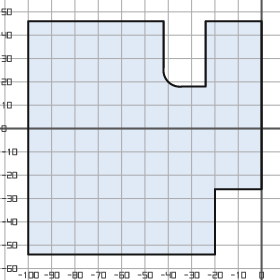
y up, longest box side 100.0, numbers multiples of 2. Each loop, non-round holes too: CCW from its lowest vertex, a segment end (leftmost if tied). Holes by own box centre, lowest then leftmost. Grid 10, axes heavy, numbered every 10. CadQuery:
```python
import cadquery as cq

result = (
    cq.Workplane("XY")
    .moveTo(-100.0, -54.0)
    .lineTo(-20.0, -54.0)
    .lineTo(-20.0, -26.0)
    .lineTo(0.0, -26.0)
    .lineTo(0.0, 46.0)
    .lineTo(-24.0, 46.0)
    .lineTo(-24.0, 18.0)
    .lineTo(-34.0, 18.0)
    .threePointArc((-40.0, 20.0), (-42.0, 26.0))
    .lineTo(-42.0, 46.0)
    .lineTo(-100.0, 46.0)
    .close()
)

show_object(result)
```